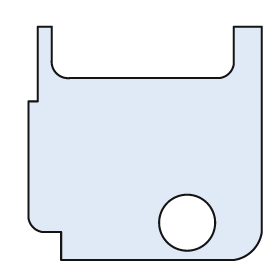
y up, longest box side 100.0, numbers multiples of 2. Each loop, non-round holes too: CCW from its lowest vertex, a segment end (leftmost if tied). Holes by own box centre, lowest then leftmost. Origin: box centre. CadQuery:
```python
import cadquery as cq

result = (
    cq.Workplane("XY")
    .moveTo(-36.0, -50.0)
    .lineTo(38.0, -50.0)
    .threePointArc((46.0, -46.0), (50.0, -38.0))
    .lineTo(50.0, 50.0)
    .lineTo(38.0, 50.0)
    .lineTo(38.0, 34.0)
    .threePointArc((36.0, 30.0), (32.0, 28.0))
    .lineTo(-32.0, 28.0)
    .threePointArc((-38.0, 30.0), (-40.0, 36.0))
    .lineTo(-40.0, 50.0)
    .lineTo(-46.0, 50.0)
    .lineTo(-46.0, 18.0)
    .lineTo(-50.0, 18.0)
    .lineTo(-50.0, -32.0)
    .threePointArc((-48.0, -36.0), (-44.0, -38.0))
    .lineTo(-36.0, -38.0)
    .close()
    .moveTo(18.0, -34.0)
    .circle(12.0)
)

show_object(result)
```